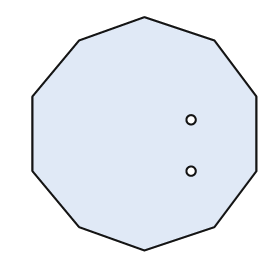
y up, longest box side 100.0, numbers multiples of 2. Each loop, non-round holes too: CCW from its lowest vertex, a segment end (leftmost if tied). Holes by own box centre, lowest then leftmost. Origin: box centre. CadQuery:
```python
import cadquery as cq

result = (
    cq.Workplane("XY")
    .moveTo(0.0, -50.0)
    .lineTo(30.0, -40.0)
    .lineTo(48.0, -16.0)
    .lineTo(48.0, 16.0)
    .lineTo(30.0, 40.0)
    .lineTo(0.0, 50.0)
    .lineTo(-28.0, 40.0)
    .lineTo(-48.0, 16.0)
    .lineTo(-48.0, -16.0)
    .lineTo(-28.0, -40.0)
    .close()
    .moveTo(20.0, -16.0)
    .circle(2.0)
    .moveTo(20.0, 6.0)
    .circle(2.0)
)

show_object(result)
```